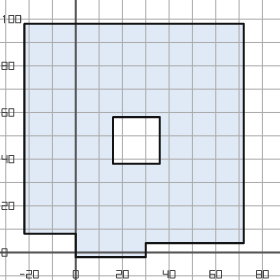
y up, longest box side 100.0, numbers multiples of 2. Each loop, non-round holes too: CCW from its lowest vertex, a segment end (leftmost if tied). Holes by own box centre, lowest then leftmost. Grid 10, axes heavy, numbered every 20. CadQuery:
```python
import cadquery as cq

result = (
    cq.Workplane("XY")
    .moveTo(0.0, -2.0)
    .lineTo(30.0, -2.0)
    .lineTo(30.0, 4.0)
    .lineTo(72.0, 4.0)
    .lineTo(72.0, 98.0)
    .lineTo(-22.0, 98.0)
    .lineTo(-22.0, 8.0)
    .lineTo(0.0, 8.0)
    .close()
    .moveTo(16.0, 38.0)
    .lineTo(36.0, 38.0)
    .lineTo(36.0, 58.0)
    .lineTo(16.0, 58.0)
    .close()
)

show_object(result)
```